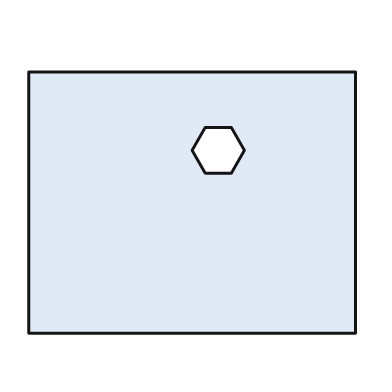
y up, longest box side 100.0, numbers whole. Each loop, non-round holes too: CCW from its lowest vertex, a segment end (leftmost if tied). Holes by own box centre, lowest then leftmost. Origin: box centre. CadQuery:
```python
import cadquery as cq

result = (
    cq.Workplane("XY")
    .moveTo(-50.0, -40.0)
    .lineTo(50.0, -40.0)
    .lineTo(50.0, 40.0)
    .lineTo(-50.0, 40.0)
    .close()
    .moveTo(4.0, 9.0)
    .lineTo(12.0, 9.0)
    .lineTo(16.0, 16.0)
    .lineTo(12.0, 23.0)
    .lineTo(4.0, 23.0)
    .lineTo(0.0, 16.0)
    .close()
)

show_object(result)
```